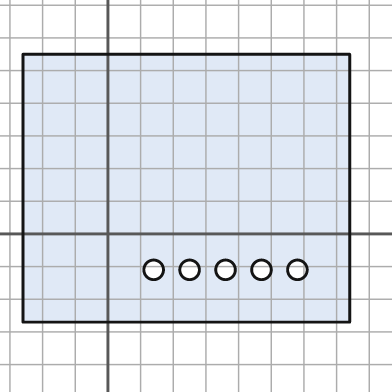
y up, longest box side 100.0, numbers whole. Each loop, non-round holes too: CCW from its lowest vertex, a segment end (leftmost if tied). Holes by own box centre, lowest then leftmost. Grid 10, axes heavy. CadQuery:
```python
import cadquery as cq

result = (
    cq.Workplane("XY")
    .moveTo(-26.0, -27.0)
    .lineTo(74.0, -27.0)
    .lineTo(74.0, 55.0)
    .lineTo(-26.0, 55.0)
    .close()
    .moveTo(14.0, -11.0)
    .circle(3.0)
    .moveTo(25.0, -11.0)
    .circle(3.0)
    .moveTo(36.0, -11.0)
    .circle(3.0)
    .moveTo(47.0, -11.0)
    .circle(3.0)
    .moveTo(58.0, -11.0)
    .circle(3.0)
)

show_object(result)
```